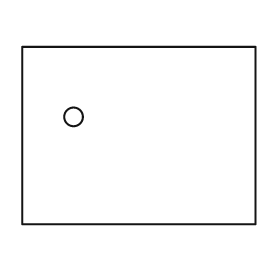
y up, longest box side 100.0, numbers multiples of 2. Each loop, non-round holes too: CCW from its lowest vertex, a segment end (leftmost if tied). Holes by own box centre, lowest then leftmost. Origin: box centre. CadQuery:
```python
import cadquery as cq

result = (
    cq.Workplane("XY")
    .moveTo(-50.0, -38.0)
    .lineTo(50.0, -38.0)
    .lineTo(50.0, 38.0)
    .lineTo(-50.0, 38.0)
    .close()
    .moveTo(-28.0, 8.0)
    .circle(4.0)
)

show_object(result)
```